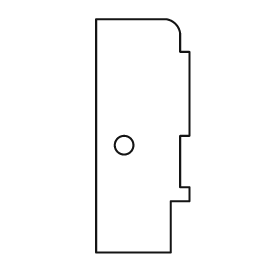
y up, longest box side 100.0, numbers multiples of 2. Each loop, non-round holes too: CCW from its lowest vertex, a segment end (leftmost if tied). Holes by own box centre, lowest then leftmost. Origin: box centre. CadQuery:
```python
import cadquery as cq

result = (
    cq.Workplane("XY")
    .moveTo(-20.0, -50.0)
    .lineTo(12.0, -50.0)
    .lineTo(12.0, -28.0)
    .lineTo(20.0, -28.0)
    .lineTo(20.0, -22.0)
    .lineTo(16.0, -22.0)
    .lineTo(16.0, 0.0)
    .lineTo(20.0, 0.0)
    .lineTo(20.0, 36.0)
    .lineTo(16.0, 36.0)
    .lineTo(16.0, 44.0)
    .threePointArc((14.0, 48.0), (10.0, 50.0))
    .lineTo(-20.0, 50.0)
    .close()
    .moveTo(-8.0, -4.0)
    .circle(4.0)
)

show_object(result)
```